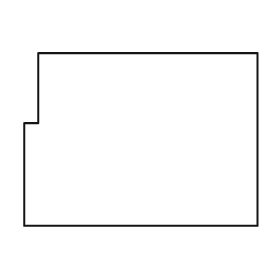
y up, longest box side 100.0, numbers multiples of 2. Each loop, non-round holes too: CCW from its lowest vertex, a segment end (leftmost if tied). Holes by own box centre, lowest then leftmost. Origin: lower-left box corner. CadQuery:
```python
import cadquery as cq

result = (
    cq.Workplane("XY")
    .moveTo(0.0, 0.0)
    .lineTo(100.0, 0.0)
    .lineTo(100.0, 74.0)
    .lineTo(6.0, 74.0)
    .lineTo(6.0, 44.0)
    .lineTo(0.0, 44.0)
    .close()
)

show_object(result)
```